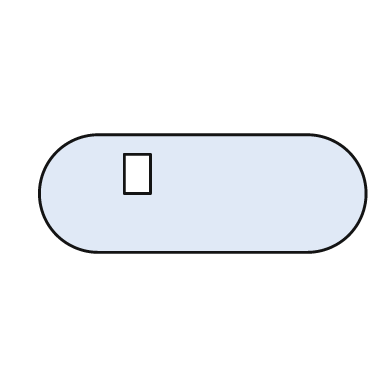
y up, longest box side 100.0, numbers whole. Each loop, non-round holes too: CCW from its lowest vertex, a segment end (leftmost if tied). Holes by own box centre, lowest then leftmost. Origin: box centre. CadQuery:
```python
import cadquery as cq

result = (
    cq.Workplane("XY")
    .moveTo(-32.0, -18.0)
    .lineTo(32.0, -18.0)
    .threePointArc((50.0, 0.0), (32.0, 18.0))
    .lineTo(-32.0, 18.0)
    .threePointArc((-50.0, 0.0), (-32.0, -18.0))
    .close()
    .moveTo(-24.0, 0.0)
    .lineTo(-16.0, 0.0)
    .lineTo(-16.0, 12.0)
    .lineTo(-24.0, 12.0)
    .close()
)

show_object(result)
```